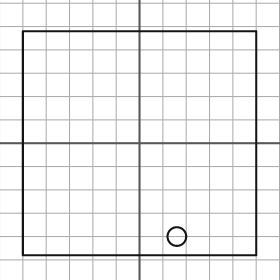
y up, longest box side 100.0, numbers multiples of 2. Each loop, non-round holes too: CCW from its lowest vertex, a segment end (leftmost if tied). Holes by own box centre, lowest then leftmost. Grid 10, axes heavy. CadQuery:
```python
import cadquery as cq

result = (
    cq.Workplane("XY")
    .moveTo(-50.0, -48.0)
    .lineTo(50.0, -48.0)
    .lineTo(50.0, 48.0)
    .lineTo(-50.0, 48.0)
    .close()
    .moveTo(16.0, -40.0)
    .circle(4.0)
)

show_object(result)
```